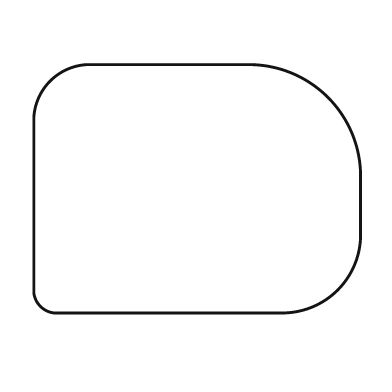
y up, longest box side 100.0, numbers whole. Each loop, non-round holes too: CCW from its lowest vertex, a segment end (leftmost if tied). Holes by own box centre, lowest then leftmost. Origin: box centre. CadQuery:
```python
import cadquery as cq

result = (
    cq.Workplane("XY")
    .moveTo(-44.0, -38.0)
    .lineTo(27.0, -38.0)
    .threePointArc((43.0, -31.0), (50.0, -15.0))
    .lineTo(50.0, 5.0)
    .threePointArc((40.0, 28.0), (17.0, 38.0))
    .lineTo(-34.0, 38.0)
    .threePointArc((-45.0, 33.0), (-50.0, 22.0))
    .lineTo(-50.0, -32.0)
    .threePointArc((-48.0, -36.0), (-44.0, -38.0))
    .close()
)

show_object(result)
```